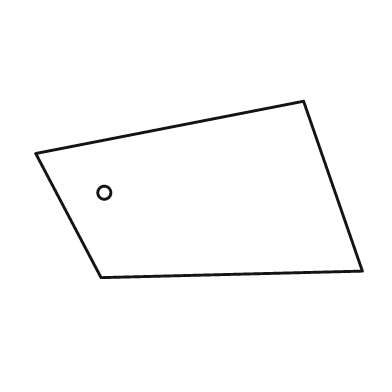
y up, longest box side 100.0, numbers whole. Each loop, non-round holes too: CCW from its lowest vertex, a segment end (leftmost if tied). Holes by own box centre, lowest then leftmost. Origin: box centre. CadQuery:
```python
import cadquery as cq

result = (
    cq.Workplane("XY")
    .moveTo(-30.0, -27.0)
    .lineTo(50.0, -25.0)
    .lineTo(32.0, 27.0)
    .lineTo(-50.0, 11.0)
    .close()
    .moveTo(-29.0, -1.0)
    .circle(2.0)
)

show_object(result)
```